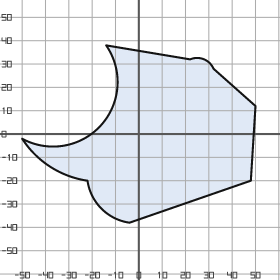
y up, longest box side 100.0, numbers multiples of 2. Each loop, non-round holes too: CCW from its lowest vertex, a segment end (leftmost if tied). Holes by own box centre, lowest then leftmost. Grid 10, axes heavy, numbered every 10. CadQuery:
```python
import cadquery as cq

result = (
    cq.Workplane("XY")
    .moveTo(-4.0, -38.0)
    .lineTo(48.0, -20.0)
    .lineTo(50.0, 12.0)
    .lineTo(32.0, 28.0)
    .threePointArc((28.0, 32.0), (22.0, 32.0))
    .lineTo(-14.0, 38.0)
    .threePointArc((-16.0, 4.0), (-50.0, -2.0))
    .threePointArc((-38.0, -14.0), (-22.0, -20.0))
    .threePointArc((-16.0, -32.0), (-4.0, -38.0))
    .close()
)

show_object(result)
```